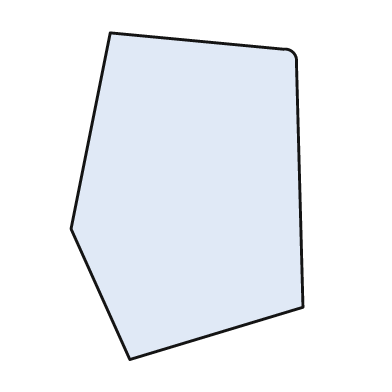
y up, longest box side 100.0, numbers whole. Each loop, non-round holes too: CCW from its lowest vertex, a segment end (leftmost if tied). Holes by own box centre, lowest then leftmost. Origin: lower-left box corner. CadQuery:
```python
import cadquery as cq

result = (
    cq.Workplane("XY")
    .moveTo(18.0, 0.0)
    .lineTo(71.0, 16.0)
    .lineTo(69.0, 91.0)
    .threePointArc((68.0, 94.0), (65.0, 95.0))
    .lineTo(12.0, 100.0)
    .lineTo(0.0, 40.0)
    .close()
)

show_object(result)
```